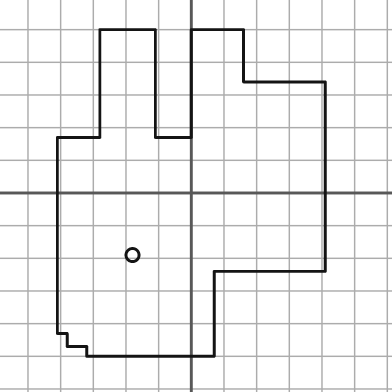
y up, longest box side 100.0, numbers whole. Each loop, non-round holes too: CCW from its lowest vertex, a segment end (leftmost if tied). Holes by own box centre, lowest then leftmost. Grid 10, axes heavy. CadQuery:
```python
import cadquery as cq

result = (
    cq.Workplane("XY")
    .moveTo(-32.0, -50.0)
    .lineTo(7.0, -50.0)
    .lineTo(7.0, -24.0)
    .lineTo(41.0, -24.0)
    .lineTo(41.0, 34.0)
    .lineTo(16.0, 34.0)
    .lineTo(16.0, 50.0)
    .lineTo(0.0, 50.0)
    .lineTo(0.0, 17.0)
    .lineTo(-11.0, 17.0)
    .lineTo(-11.0, 50.0)
    .lineTo(-28.0, 50.0)
    .lineTo(-28.0, 17.0)
    .lineTo(-41.0, 17.0)
    .lineTo(-41.0, -43.0)
    .lineTo(-38.0, -43.0)
    .lineTo(-38.0, -47.0)
    .lineTo(-32.0, -47.0)
    .close()
    .moveTo(-18.0, -19.0)
    .circle(2.0)
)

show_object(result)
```